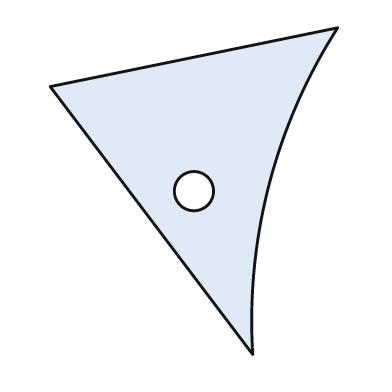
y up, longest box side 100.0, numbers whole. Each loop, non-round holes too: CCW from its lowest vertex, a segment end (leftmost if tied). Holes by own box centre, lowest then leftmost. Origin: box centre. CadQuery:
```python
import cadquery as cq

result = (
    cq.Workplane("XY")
    .moveTo(18.0, -50.0)
    .threePointArc((23.0, 2.0), (44.0, 50.0))
    .lineTo(-44.0, 32.0)
    .close()
    .moveTo(0.0, 0.0)
    .circle(6.0)
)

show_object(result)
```